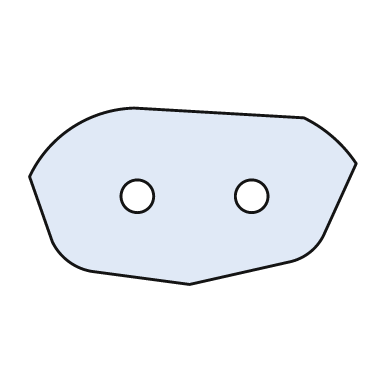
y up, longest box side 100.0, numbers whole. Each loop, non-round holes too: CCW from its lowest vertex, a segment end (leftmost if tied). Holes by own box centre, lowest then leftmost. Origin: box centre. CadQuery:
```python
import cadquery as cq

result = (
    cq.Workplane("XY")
    .moveTo(-1.0, -27.0)
    .lineTo(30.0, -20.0)
    .threePointArc((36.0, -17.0), (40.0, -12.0))
    .lineTo(50.0, 10.0)
    .threePointArc((43.0, 18.0), (34.0, 24.0))
    .lineTo(-18.0, 27.0)
    .threePointArc((-37.0, 21.0), (-50.0, 6.0))
    .lineTo(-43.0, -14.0)
    .threePointArc((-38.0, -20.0), (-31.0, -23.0))
    .close()
    .moveTo(-17.0, 0.0)
    .circle(5.0)
    .moveTo(18.0, 0.0)
    .circle(5.0)
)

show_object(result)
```